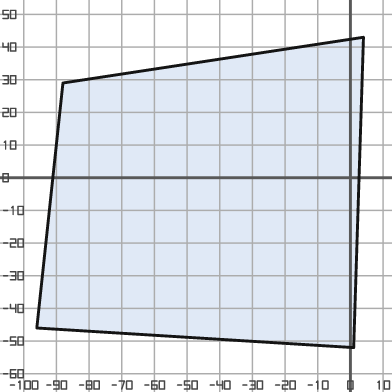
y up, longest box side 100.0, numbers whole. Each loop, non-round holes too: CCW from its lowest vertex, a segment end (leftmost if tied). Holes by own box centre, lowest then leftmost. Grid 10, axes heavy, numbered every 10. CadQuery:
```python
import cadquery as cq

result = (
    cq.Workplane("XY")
    .moveTo(1.0, -52.0)
    .lineTo(4.0, 43.0)
    .lineTo(-88.0, 29.0)
    .lineTo(-96.0, -46.0)
    .close()
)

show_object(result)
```